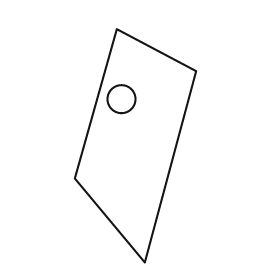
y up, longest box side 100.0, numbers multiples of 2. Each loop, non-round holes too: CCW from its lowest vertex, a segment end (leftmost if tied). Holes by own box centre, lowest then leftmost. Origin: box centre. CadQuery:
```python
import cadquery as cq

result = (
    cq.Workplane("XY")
    .moveTo(4.0, -50.0)
    .lineTo(26.0, 32.0)
    .lineTo(-8.0, 50.0)
    .lineTo(-26.0, -14.0)
    .close()
    .moveTo(-6.0, 20.0)
    .circle(6.0)
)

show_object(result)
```